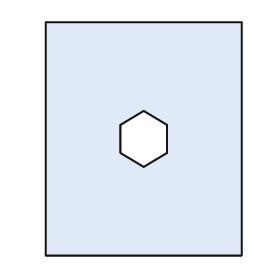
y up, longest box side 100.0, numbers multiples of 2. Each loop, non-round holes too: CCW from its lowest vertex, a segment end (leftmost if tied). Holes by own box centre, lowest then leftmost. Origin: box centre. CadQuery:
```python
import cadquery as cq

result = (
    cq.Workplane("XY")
    .moveTo(-42.0, -50.0)
    .lineTo(42.0, -50.0)
    .lineTo(42.0, 50.0)
    .lineTo(-42.0, 50.0)
    .close()
    .moveTo(0.0, -12.0)
    .lineTo(10.0, -6.0)
    .lineTo(10.0, 6.0)
    .lineTo(0.0, 12.0)
    .lineTo(-10.0, 6.0)
    .lineTo(-10.0, -6.0)
    .close()
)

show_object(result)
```